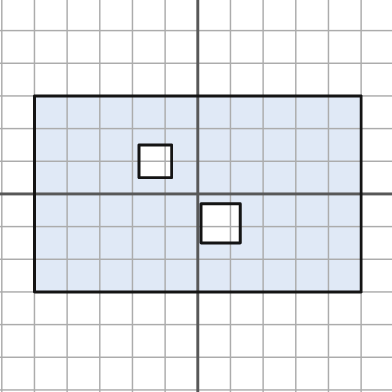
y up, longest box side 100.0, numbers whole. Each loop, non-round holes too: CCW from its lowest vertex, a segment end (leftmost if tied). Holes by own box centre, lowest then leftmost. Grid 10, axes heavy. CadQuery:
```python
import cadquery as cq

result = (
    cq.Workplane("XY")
    .moveTo(-50.0, -30.0)
    .lineTo(50.0, -30.0)
    .lineTo(50.0, 30.0)
    .lineTo(-50.0, 30.0)
    .close()
    .moveTo(1.0, -15.0)
    .lineTo(13.0, -15.0)
    .lineTo(13.0, -3.0)
    .lineTo(1.0, -3.0)
    .close()
    .moveTo(-18.0, 5.0)
    .lineTo(-8.0, 5.0)
    .lineTo(-8.0, 15.0)
    .lineTo(-18.0, 15.0)
    .close()
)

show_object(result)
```